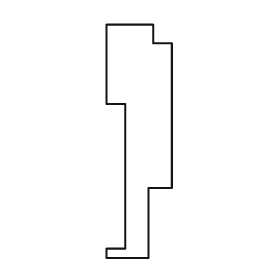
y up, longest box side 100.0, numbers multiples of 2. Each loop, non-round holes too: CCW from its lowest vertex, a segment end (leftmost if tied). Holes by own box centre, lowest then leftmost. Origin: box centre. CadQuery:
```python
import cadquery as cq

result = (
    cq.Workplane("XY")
    .moveTo(-14.0, -50.0)
    .lineTo(4.0, -50.0)
    .lineTo(4.0, -20.0)
    .lineTo(14.0, -20.0)
    .lineTo(14.0, 42.0)
    .lineTo(6.0, 42.0)
    .lineTo(6.0, 50.0)
    .lineTo(-14.0, 50.0)
    .lineTo(-14.0, 16.0)
    .lineTo(-6.0, 16.0)
    .lineTo(-6.0, -46.0)
    .lineTo(-14.0, -46.0)
    .close()
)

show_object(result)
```